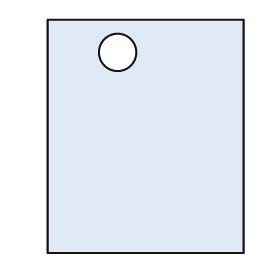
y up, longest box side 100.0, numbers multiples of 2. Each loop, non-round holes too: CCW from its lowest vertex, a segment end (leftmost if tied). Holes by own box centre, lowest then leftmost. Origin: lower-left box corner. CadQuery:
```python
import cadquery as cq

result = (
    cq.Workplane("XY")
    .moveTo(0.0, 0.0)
    .lineTo(84.0, 0.0)
    .lineTo(84.0, 100.0)
    .lineTo(0.0, 100.0)
    .close()
    .moveTo(30.0, 86.0)
    .circle(8.0)
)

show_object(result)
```